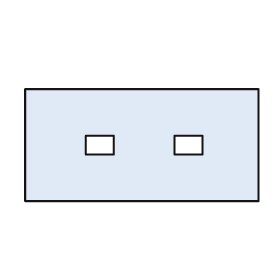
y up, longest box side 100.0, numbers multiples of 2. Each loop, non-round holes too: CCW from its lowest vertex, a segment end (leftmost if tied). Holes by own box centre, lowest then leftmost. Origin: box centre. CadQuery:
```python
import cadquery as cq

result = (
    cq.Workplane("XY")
    .moveTo(-50.0, -24.0)
    .lineTo(50.0, -24.0)
    .lineTo(50.0, 24.0)
    .lineTo(-50.0, 24.0)
    .close()
    .moveTo(-24.0, -4.0)
    .lineTo(-12.0, -4.0)
    .lineTo(-12.0, 4.0)
    .lineTo(-24.0, 4.0)
    .close()
    .moveTo(14.0, -4.0)
    .lineTo(26.0, -4.0)
    .lineTo(26.0, 4.0)
    .lineTo(14.0, 4.0)
    .close()
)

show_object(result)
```